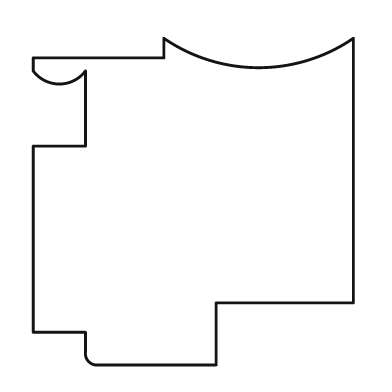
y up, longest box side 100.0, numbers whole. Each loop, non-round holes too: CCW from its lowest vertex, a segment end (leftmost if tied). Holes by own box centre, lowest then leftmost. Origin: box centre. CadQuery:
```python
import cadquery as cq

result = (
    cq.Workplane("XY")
    .moveTo(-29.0, -50.0)
    .lineTo(7.0, -50.0)
    .lineTo(7.0, -31.0)
    .lineTo(49.0, -31.0)
    .lineTo(49.0, 50.0)
    .threePointArc((20.0, 41.0), (-9.0, 50.0))
    .lineTo(-9.0, 44.0)
    .lineTo(-49.0, 44.0)
    .lineTo(-49.0, 40.0)
    .threePointArc((-41.0, 36.0), (-33.0, 40.0))
    .lineTo(-33.0, 17.0)
    .lineTo(-49.0, 17.0)
    .lineTo(-49.0, -40.0)
    .lineTo(-33.0, -40.0)
    .lineTo(-33.0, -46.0)
    .threePointArc((-32.0, -49.0), (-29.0, -50.0))
    .close()
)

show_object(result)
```